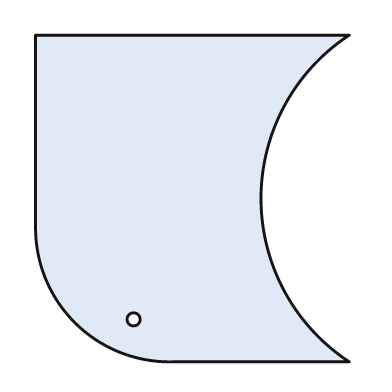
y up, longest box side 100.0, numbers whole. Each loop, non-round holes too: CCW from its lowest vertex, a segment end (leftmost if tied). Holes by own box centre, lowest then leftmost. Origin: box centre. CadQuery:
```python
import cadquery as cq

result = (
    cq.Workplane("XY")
    .moveTo(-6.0, -50.0)
    .lineTo(48.0, -50.0)
    .threePointArc((21.0, 0.0), (48.0, 50.0))
    .lineTo(-48.0, 50.0)
    .lineTo(-48.0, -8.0)
    .threePointArc((-36.0, -38.0), (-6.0, -50.0))
    .close()
    .moveTo(-18.0, -37.0)
    .circle(2.0)
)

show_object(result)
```